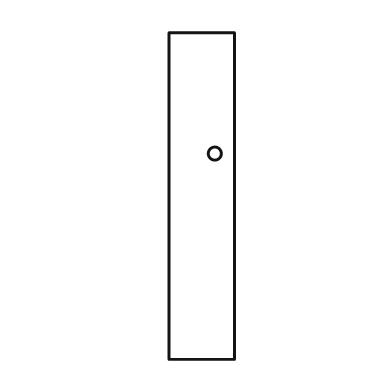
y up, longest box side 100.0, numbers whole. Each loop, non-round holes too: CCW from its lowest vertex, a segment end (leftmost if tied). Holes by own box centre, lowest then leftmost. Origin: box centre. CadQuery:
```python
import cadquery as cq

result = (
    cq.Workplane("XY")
    .moveTo(-10.0, -50.0)
    .lineTo(10.0, -50.0)
    .lineTo(10.0, 50.0)
    .lineTo(-10.0, 50.0)
    .close()
    .moveTo(4.0, 13.0)
    .circle(2.0)
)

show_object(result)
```